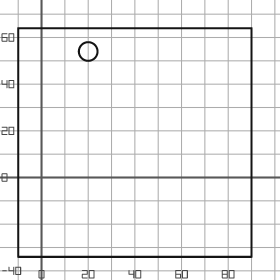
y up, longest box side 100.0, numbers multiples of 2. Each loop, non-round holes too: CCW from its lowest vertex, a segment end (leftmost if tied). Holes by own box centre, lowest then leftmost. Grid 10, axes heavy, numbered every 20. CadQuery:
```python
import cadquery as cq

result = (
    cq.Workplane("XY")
    .moveTo(-10.0, -34.0)
    .lineTo(90.0, -34.0)
    .lineTo(90.0, 64.0)
    .lineTo(-10.0, 64.0)
    .close()
    .moveTo(20.0, 54.0)
    .circle(4.0)
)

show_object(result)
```